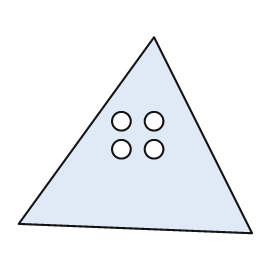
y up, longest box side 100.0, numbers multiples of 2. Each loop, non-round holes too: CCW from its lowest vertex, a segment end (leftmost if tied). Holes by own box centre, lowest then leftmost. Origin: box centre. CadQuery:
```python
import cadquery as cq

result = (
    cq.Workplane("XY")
    .moveTo(50.0, -42.0)
    .lineTo(8.0, 42.0)
    .lineTo(-50.0, -38.0)
    .close()
    .moveTo(-6.0, -6.0)
    .circle(4.0)
    .moveTo(8.0, -6.0)
    .circle(4.0)
    .moveTo(-6.0, 6.0)
    .circle(4.0)
    .moveTo(8.0, 6.0)
    .circle(4.0)
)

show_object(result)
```